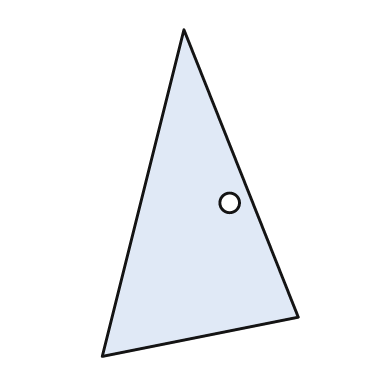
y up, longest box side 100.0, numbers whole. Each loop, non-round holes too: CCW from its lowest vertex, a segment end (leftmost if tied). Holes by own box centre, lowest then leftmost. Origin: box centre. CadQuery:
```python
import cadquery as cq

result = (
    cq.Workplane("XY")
    .moveTo(-30.0, -50.0)
    .lineTo(30.0, -38.0)
    .lineTo(-5.0, 50.0)
    .close()
    .moveTo(9.0, -3.0)
    .circle(3.0)
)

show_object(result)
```